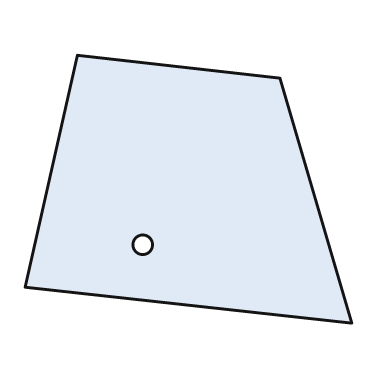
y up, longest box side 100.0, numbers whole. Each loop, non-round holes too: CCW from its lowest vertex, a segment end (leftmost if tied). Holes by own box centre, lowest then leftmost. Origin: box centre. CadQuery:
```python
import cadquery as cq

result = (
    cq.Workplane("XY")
    .moveTo(50.0, -41.0)
    .lineTo(28.0, 34.0)
    .lineTo(-34.0, 41.0)
    .lineTo(-50.0, -30.0)
    .close()
    .moveTo(-14.0, -17.0)
    .circle(3.0)
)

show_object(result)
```